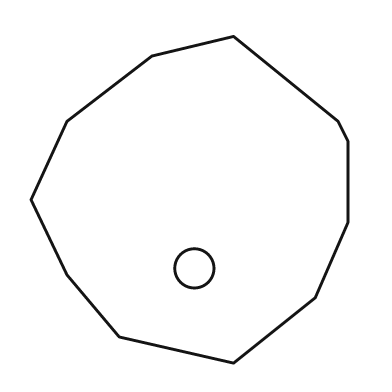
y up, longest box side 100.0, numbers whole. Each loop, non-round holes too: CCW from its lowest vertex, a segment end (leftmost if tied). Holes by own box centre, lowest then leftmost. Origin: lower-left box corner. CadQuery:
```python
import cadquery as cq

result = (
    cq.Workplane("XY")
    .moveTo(62.0, 0.0)
    .lineTo(87.0, 20.0)
    .lineTo(97.0, 43.0)
    .lineTo(97.0, 68.0)
    .lineTo(94.0, 74.0)
    .lineTo(62.0, 100.0)
    .lineTo(37.0, 94.0)
    .lineTo(11.0, 74.0)
    .lineTo(0.0, 50.0)
    .lineTo(11.0, 27.0)
    .lineTo(27.0, 8.0)
    .close()
    .moveTo(50.0, 29.0)
    .circle(6.0)
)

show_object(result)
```